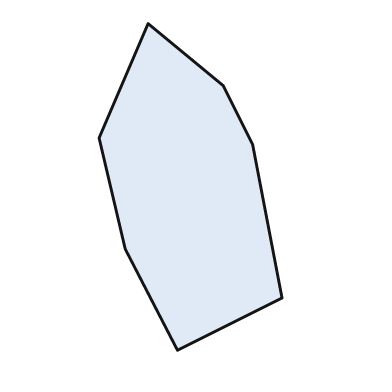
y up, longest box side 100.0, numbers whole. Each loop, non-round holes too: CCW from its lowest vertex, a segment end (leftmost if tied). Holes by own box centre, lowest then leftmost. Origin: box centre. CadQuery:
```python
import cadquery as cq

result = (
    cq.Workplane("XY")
    .moveTo(-4.0, -50.0)
    .lineTo(28.0, -34.0)
    .lineTo(19.0, 13.0)
    .lineTo(10.0, 31.0)
    .lineTo(-13.0, 50.0)
    .lineTo(-28.0, 15.0)
    .lineTo(-20.0, -19.0)
    .close()
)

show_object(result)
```